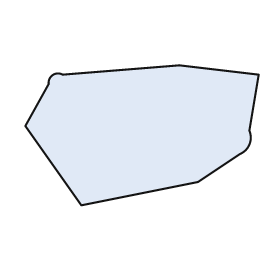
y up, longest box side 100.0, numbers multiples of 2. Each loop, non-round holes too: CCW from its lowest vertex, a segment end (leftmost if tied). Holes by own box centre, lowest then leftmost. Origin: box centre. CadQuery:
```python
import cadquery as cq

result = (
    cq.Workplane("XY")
    .moveTo(-26.0, -30.0)
    .lineTo(24.0, -20.0)
    .lineTo(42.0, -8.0)
    .threePointArc((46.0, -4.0), (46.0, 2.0))
    .lineTo(50.0, 26.0)
    .lineTo(16.0, 30.0)
    .lineTo(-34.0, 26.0)
    .threePointArc((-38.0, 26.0), (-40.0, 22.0))
    .lineTo(-50.0, 4.0)
    .close()
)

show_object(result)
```